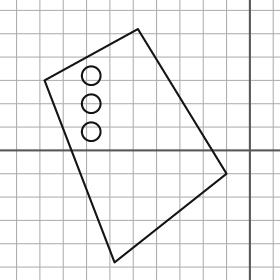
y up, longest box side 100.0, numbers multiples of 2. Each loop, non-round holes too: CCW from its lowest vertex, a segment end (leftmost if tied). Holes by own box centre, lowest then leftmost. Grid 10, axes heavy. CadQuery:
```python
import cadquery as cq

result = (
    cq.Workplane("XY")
    .moveTo(-58.0, -48.0)
    .lineTo(-10.0, -10.0)
    .lineTo(-48.0, 52.0)
    .lineTo(-88.0, 30.0)
    .close()
    .moveTo(-68.0, 8.0)
    .circle(4.0)
    .moveTo(-68.0, 20.0)
    .circle(4.0)
    .moveTo(-68.0, 32.0)
    .circle(4.0)
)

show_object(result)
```